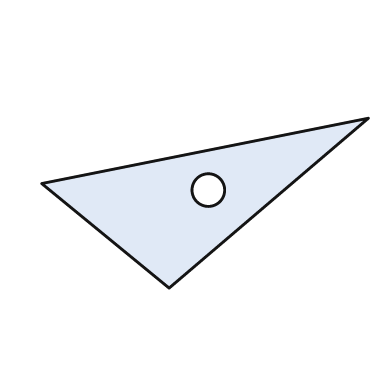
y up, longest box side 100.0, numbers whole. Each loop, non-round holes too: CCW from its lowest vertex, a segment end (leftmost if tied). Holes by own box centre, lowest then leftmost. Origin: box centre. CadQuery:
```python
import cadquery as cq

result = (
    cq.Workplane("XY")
    .moveTo(-11.0, -26.0)
    .lineTo(50.0, 26.0)
    .lineTo(-50.0, 6.0)
    .close()
    .moveTo(1.0, 4.0)
    .circle(5.0)
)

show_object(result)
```